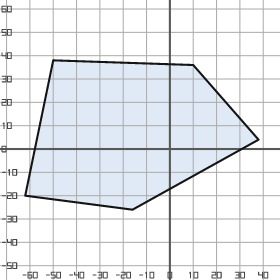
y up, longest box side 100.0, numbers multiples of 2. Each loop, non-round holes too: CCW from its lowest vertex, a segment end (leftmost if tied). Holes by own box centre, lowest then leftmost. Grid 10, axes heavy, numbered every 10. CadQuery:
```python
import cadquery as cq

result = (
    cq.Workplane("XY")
    .moveTo(-16.0, -26.0)
    .lineTo(38.0, 4.0)
    .lineTo(10.0, 36.0)
    .lineTo(-50.0, 38.0)
    .lineTo(-62.0, -20.0)
    .close()
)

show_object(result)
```